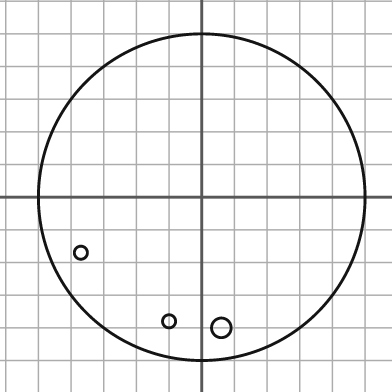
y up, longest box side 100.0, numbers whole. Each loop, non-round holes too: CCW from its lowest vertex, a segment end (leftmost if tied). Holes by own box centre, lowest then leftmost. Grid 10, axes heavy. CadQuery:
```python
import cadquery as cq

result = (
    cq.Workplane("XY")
    .moveTo(0.0, 0.0)
    .circle(50.0)
    .moveTo(6.0, -40.0)
    .circle(3.0)
    .moveTo(-10.0, -38.0)
    .circle(2.0)
    .moveTo(-37.0, -17.0)
    .circle(2.0)
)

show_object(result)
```